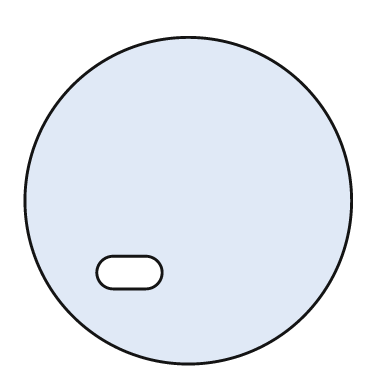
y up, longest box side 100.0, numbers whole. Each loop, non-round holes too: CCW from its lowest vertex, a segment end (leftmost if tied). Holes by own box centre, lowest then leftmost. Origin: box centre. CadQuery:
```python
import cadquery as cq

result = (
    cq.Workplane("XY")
    .moveTo(0.0, 0.0)
    .circle(50.0)
    .moveTo(-23.0, -27.0)
    .lineTo(-13.0, -27.0)
    .threePointArc((-8.0, -22.0), (-13.0, -17.0))
    .lineTo(-23.0, -17.0)
    .threePointArc((-28.0, -22.0), (-23.0, -27.0))
    .close()
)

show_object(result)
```